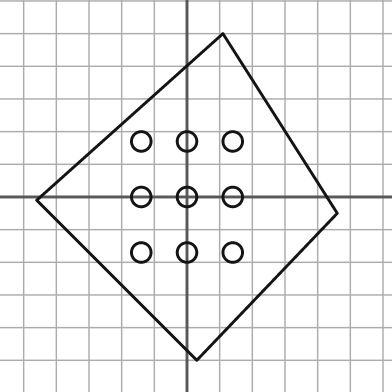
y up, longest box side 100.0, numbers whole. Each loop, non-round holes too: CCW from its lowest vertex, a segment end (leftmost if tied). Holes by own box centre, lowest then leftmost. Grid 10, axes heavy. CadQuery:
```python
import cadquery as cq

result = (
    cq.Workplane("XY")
    .moveTo(3.0, -50.0)
    .lineTo(46.0, -5.0)
    .lineTo(11.0, 50.0)
    .lineTo(-46.0, -1.0)
    .close()
    .moveTo(-14.0, -17.0)
    .circle(3.0)
    .moveTo(0.0, -17.0)
    .circle(3.0)
    .moveTo(14.0, -17.0)
    .circle(3.0)
    .moveTo(-14.0, 0.0)
    .circle(3.0)
    .moveTo(0.0, 0.0)
    .circle(3.0)
    .moveTo(14.0, 0.0)
    .circle(3.0)
    .moveTo(-14.0, 17.0)
    .circle(3.0)
    .moveTo(0.0, 17.0)
    .circle(3.0)
    .moveTo(14.0, 17.0)
    .circle(3.0)
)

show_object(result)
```